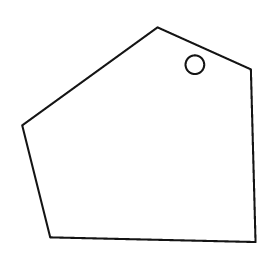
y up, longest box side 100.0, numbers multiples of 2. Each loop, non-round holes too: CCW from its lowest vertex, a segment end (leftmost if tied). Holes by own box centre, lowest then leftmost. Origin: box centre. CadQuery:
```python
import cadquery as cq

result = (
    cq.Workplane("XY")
    .moveTo(50.0, -46.0)
    .lineTo(48.0, 28.0)
    .lineTo(8.0, 46.0)
    .lineTo(-50.0, 4.0)
    .lineTo(-38.0, -44.0)
    .close()
    .moveTo(24.0, 30.0)
    .circle(4.0)
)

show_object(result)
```